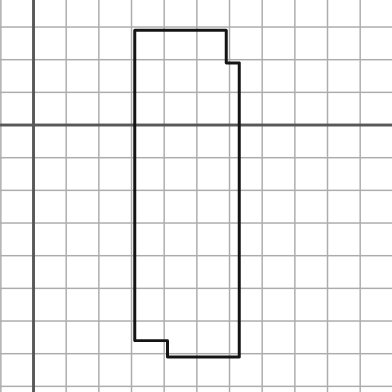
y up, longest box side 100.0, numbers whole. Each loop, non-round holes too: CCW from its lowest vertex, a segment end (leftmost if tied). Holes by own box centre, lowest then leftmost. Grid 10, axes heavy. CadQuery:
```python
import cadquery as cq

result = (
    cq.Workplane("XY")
    .moveTo(41.0, -71.0)
    .lineTo(63.0, -71.0)
    .lineTo(63.0, 19.0)
    .lineTo(59.0, 19.0)
    .lineTo(59.0, 29.0)
    .lineTo(31.0, 29.0)
    .lineTo(31.0, -66.0)
    .lineTo(41.0, -66.0)
    .close()
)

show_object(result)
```